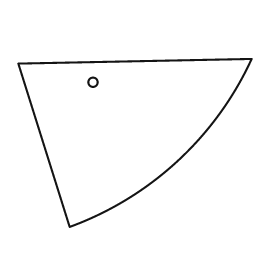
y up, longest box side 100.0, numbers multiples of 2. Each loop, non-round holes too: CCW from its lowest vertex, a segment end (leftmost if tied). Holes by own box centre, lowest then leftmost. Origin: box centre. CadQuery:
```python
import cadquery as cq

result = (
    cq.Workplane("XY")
    .moveTo(-28.0, -36.0)
    .threePointArc((18.0, -8.0), (50.0, 36.0))
    .lineTo(-50.0, 34.0)
    .close()
    .moveTo(-18.0, 26.0)
    .circle(2.0)
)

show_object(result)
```